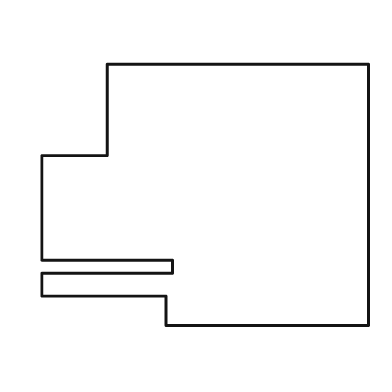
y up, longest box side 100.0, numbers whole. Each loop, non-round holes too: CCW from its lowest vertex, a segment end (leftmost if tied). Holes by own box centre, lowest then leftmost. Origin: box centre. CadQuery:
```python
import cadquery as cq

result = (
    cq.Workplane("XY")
    .moveTo(-12.0, -40.0)
    .lineTo(50.0, -40.0)
    .lineTo(50.0, 40.0)
    .lineTo(-30.0, 40.0)
    .lineTo(-30.0, 12.0)
    .lineTo(-50.0, 12.0)
    .lineTo(-50.0, -20.0)
    .lineTo(-10.0, -20.0)
    .lineTo(-10.0, -24.0)
    .lineTo(-50.0, -24.0)
    .lineTo(-50.0, -31.0)
    .lineTo(-12.0, -31.0)
    .close()
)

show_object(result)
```